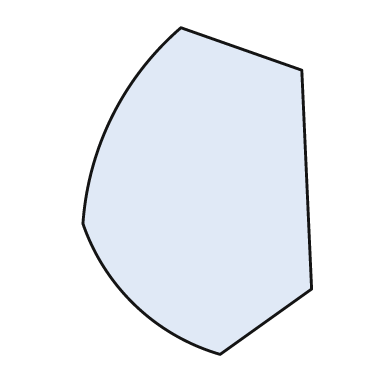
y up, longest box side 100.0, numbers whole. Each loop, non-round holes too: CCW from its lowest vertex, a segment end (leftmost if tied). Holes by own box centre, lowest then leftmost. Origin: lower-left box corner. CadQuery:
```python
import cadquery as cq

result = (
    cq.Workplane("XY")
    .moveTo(42.0, 0.0)
    .lineTo(70.0, 20.0)
    .lineTo(67.0, 87.0)
    .lineTo(30.0, 100.0)
    .threePointArc((9.0, 73.0), (0.0, 40.0))
    .threePointArc((16.0, 15.0), (42.0, 0.0))
    .close()
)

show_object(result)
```